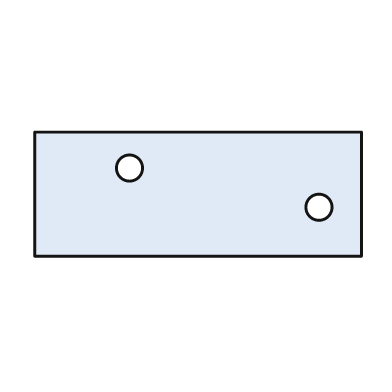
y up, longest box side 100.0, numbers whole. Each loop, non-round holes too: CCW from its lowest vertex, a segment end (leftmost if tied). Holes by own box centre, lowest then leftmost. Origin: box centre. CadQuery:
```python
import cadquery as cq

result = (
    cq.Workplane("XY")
    .moveTo(-50.0, -19.0)
    .lineTo(50.0, -19.0)
    .lineTo(50.0, 19.0)
    .lineTo(-50.0, 19.0)
    .close()
    .moveTo(37.0, -4.0)
    .circle(4.0)
    .moveTo(-21.0, 8.0)
    .circle(4.0)
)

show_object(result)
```